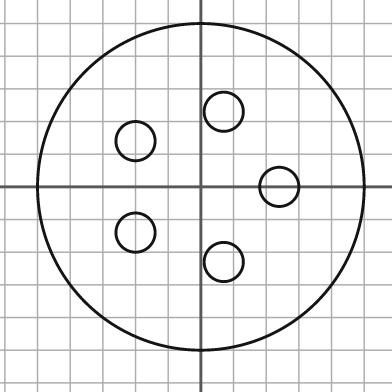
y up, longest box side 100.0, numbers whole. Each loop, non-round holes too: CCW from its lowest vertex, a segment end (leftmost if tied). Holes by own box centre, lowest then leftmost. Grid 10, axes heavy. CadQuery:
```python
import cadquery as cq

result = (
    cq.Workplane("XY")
    .moveTo(0.0, 0.0)
    .circle(50.0)
    .moveTo(7.0, -23.0)
    .circle(6.0)
    .moveTo(-20.0, -14.0)
    .circle(6.0)
    .moveTo(24.0, 0.0)
    .circle(6.0)
    .moveTo(-20.0, 14.0)
    .circle(6.0)
    .moveTo(7.0, 23.0)
    .circle(6.0)
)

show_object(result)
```